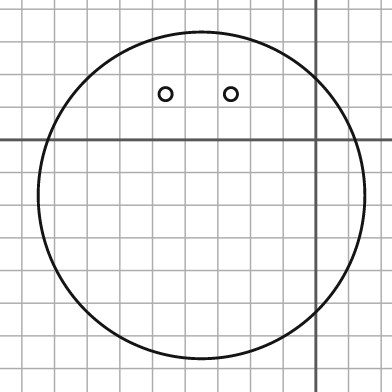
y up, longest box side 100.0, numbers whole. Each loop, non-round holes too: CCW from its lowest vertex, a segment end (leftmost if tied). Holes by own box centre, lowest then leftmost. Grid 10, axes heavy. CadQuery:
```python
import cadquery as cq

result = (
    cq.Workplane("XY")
    .moveTo(-35.0, -17.0)
    .circle(50.0)
    .moveTo(-46.0, 14.0)
    .circle(2.0)
    .moveTo(-26.0, 14.0)
    .circle(2.0)
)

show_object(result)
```